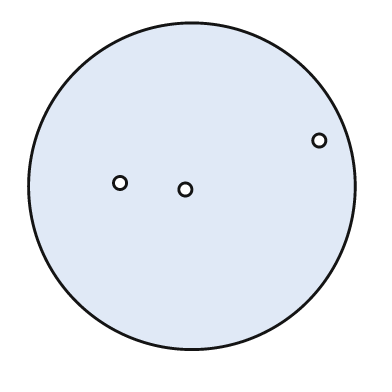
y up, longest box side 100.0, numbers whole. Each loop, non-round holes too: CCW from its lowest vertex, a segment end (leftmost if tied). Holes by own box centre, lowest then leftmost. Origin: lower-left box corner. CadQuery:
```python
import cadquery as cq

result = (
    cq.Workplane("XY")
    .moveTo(50.0, 50.0)
    .circle(50.0)
    .moveTo(48.0, 49.0)
    .circle(2.0)
    .moveTo(28.0, 51.0)
    .circle(2.0)
    .moveTo(89.0, 64.0)
    .circle(2.0)
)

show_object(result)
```